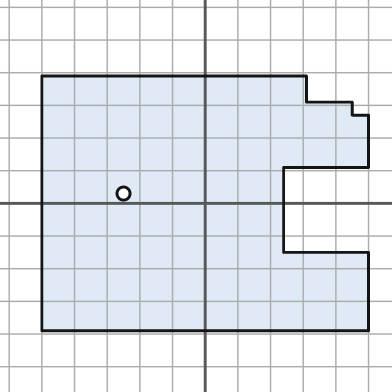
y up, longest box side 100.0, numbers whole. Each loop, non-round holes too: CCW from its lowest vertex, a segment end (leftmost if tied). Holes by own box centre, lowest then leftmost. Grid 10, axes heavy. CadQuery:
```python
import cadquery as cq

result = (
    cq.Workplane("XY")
    .moveTo(-50.0, -39.0)
    .lineTo(50.0, -39.0)
    .lineTo(50.0, -15.0)
    .lineTo(24.0, -15.0)
    .lineTo(24.0, 11.0)
    .lineTo(50.0, 11.0)
    .lineTo(50.0, 27.0)
    .lineTo(45.0, 27.0)
    .lineTo(45.0, 31.0)
    .lineTo(31.0, 31.0)
    .lineTo(31.0, 39.0)
    .lineTo(-50.0, 39.0)
    .close()
    .moveTo(-25.0, 3.0)
    .circle(2.0)
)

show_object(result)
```